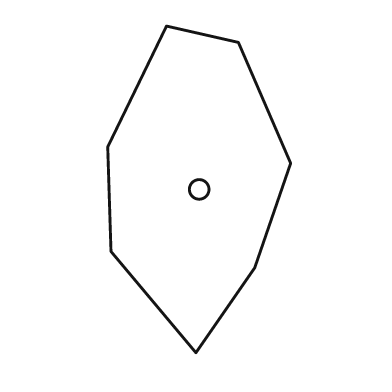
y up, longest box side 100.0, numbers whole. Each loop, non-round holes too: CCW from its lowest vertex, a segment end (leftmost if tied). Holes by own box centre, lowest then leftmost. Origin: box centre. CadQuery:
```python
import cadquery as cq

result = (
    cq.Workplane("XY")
    .moveTo(-1.0, -50.0)
    .lineTo(17.0, -24.0)
    .lineTo(28.0, 8.0)
    .lineTo(12.0, 45.0)
    .lineTo(-10.0, 50.0)
    .lineTo(-28.0, 13.0)
    .lineTo(-27.0, -19.0)
    .close()
    .moveTo(0.0, 0.0)
    .circle(3.0)
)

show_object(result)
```